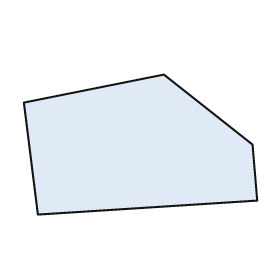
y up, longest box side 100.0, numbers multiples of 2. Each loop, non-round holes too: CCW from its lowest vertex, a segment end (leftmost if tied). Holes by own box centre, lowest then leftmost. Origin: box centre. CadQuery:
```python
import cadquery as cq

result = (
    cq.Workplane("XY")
    .moveTo(-44.0, -30.0)
    .lineTo(50.0, -24.0)
    .lineTo(48.0, 0.0)
    .lineTo(10.0, 30.0)
    .lineTo(-50.0, 18.0)
    .close()
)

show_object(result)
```